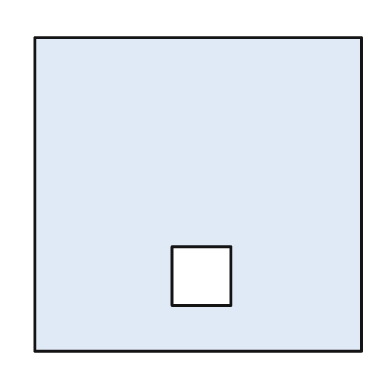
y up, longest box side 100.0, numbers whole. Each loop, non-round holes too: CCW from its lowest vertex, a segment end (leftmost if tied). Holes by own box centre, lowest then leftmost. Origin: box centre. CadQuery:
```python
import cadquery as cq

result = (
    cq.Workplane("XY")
    .moveTo(-50.0, -48.0)
    .lineTo(50.0, -48.0)
    .lineTo(50.0, 48.0)
    .lineTo(-50.0, 48.0)
    .close()
    .moveTo(-8.0, -34.0)
    .lineTo(10.0, -34.0)
    .lineTo(10.0, -16.0)
    .lineTo(-8.0, -16.0)
    .close()
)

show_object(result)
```